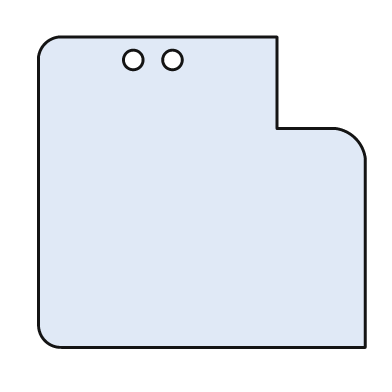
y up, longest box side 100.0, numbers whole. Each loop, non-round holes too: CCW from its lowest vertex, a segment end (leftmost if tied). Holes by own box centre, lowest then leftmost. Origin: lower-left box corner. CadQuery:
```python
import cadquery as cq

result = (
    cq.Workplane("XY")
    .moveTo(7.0, 0.0)
    .lineTo(100.0, 0.0)
    .lineTo(100.0, 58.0)
    .threePointArc((97.0, 64.0), (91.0, 67.0))
    .lineTo(73.0, 67.0)
    .lineTo(73.0, 95.0)
    .lineTo(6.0, 95.0)
    .threePointArc((2.0, 93.0), (0.0, 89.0))
    .lineTo(0.0, 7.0)
    .threePointArc((2.0, 2.0), (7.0, 0.0))
    .close()
    .moveTo(29.0, 88.0)
    .circle(3.0)
    .moveTo(41.0, 88.0)
    .circle(3.0)
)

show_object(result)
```